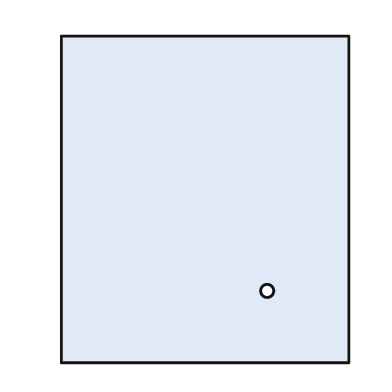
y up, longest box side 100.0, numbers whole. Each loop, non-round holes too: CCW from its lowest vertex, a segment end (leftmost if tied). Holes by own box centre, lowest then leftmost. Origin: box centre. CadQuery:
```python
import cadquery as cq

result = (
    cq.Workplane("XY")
    .moveTo(-44.0, -50.0)
    .lineTo(44.0, -50.0)
    .lineTo(44.0, 50.0)
    .lineTo(-44.0, 50.0)
    .close()
    .moveTo(19.0, -28.0)
    .circle(2.0)
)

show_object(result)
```